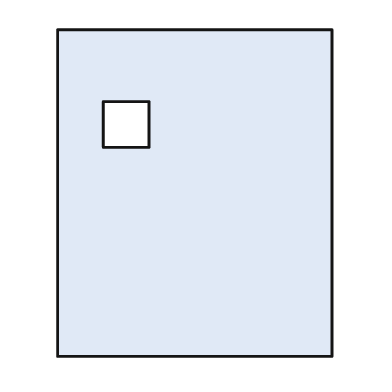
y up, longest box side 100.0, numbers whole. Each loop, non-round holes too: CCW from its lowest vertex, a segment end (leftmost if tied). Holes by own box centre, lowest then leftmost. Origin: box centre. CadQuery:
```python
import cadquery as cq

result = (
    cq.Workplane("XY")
    .moveTo(-42.0, -50.0)
    .lineTo(42.0, -50.0)
    .lineTo(42.0, 50.0)
    .lineTo(-42.0, 50.0)
    .close()
    .moveTo(-28.0, 14.0)
    .lineTo(-14.0, 14.0)
    .lineTo(-14.0, 28.0)
    .lineTo(-28.0, 28.0)
    .close()
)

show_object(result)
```